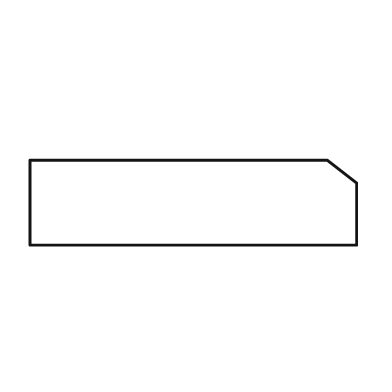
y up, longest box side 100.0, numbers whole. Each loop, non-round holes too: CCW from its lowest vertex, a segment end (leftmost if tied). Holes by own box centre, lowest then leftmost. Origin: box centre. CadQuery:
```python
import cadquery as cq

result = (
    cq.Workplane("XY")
    .moveTo(-50.0, -13.0)
    .lineTo(50.0, -13.0)
    .lineTo(50.0, 6.0)
    .lineTo(41.0, 13.0)
    .lineTo(-50.0, 13.0)
    .close()
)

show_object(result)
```